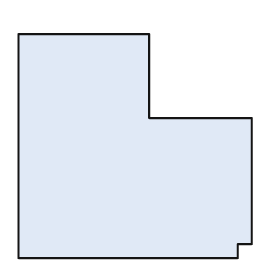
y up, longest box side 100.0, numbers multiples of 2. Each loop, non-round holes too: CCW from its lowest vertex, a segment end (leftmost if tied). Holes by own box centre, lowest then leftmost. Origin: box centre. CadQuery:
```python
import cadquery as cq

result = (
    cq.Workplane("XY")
    .moveTo(-50.0, -48.0)
    .lineTo(44.0, -48.0)
    .lineTo(44.0, -42.0)
    .lineTo(50.0, -42.0)
    .lineTo(50.0, 12.0)
    .lineTo(6.0, 12.0)
    .lineTo(6.0, 48.0)
    .lineTo(-50.0, 48.0)
    .close()
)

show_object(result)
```